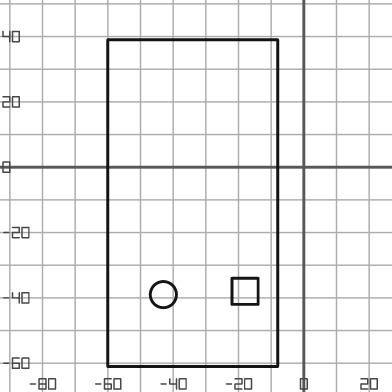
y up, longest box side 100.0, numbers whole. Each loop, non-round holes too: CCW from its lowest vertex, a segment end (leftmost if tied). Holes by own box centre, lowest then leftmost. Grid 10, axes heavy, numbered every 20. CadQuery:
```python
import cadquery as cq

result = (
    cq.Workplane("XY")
    .moveTo(-60.0, -61.0)
    .lineTo(-8.0, -61.0)
    .lineTo(-8.0, 39.0)
    .lineTo(-60.0, 39.0)
    .close()
    .moveTo(-43.0, -39.0)
    .circle(4.0)
    .moveTo(-22.0, -42.0)
    .lineTo(-14.0, -42.0)
    .lineTo(-14.0, -34.0)
    .lineTo(-22.0, -34.0)
    .close()
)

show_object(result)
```